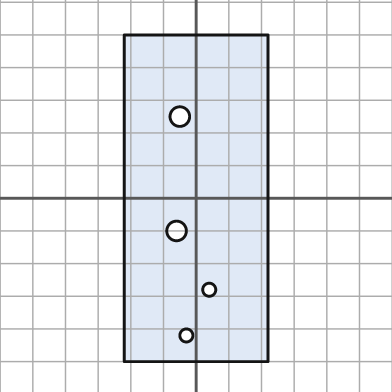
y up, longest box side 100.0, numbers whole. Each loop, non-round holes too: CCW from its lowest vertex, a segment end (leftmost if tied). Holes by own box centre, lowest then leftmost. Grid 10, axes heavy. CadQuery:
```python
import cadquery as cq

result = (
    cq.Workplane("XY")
    .moveTo(-22.0, -50.0)
    .lineTo(22.0, -50.0)
    .lineTo(22.0, 50.0)
    .lineTo(-22.0, 50.0)
    .close()
    .moveTo(-3.0, -42.0)
    .circle(2.0)
    .moveTo(4.0, -28.0)
    .circle(2.0)
    .moveTo(-6.0, -10.0)
    .circle(3.0)
    .moveTo(-5.0, 25.0)
    .circle(3.0)
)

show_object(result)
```